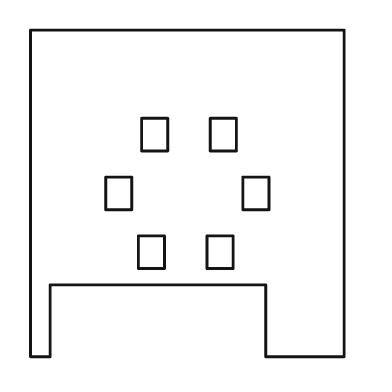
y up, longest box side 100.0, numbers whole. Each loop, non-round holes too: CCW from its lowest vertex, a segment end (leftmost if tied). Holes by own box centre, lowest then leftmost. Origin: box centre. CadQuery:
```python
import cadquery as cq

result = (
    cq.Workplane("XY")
    .moveTo(-48.0, -50.0)
    .lineTo(-42.0, -50.0)
    .lineTo(-42.0, -28.0)
    .lineTo(24.0, -28.0)
    .lineTo(24.0, -50.0)
    .lineTo(48.0, -50.0)
    .lineTo(48.0, 50.0)
    .lineTo(-48.0, 50.0)
    .close()
    .moveTo(-15.0, -23.0)
    .lineTo(-7.0, -23.0)
    .lineTo(-7.0, -13.0)
    .lineTo(-15.0, -13.0)
    .close()
    .moveTo(6.0, -23.0)
    .lineTo(14.0, -23.0)
    .lineTo(14.0, -13.0)
    .lineTo(6.0, -13.0)
    .close()
    .moveTo(-25.0, -5.0)
    .lineTo(-17.0, -5.0)
    .lineTo(-17.0, 5.0)
    .lineTo(-25.0, 5.0)
    .close()
    .moveTo(17.0, -5.0)
    .lineTo(25.0, -5.0)
    .lineTo(25.0, 5.0)
    .lineTo(17.0, 5.0)
    .close()
    .moveTo(-14.0, 13.0)
    .lineTo(-6.0, 13.0)
    .lineTo(-6.0, 23.0)
    .lineTo(-14.0, 23.0)
    .close()
    .moveTo(7.0, 13.0)
    .lineTo(15.0, 13.0)
    .lineTo(15.0, 23.0)
    .lineTo(7.0, 23.0)
    .close()
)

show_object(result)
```